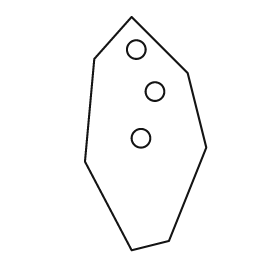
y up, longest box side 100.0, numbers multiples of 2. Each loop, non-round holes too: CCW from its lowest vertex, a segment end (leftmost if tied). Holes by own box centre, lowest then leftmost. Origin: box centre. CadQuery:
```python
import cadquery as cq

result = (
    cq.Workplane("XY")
    .moveTo(-6.0, -50.0)
    .lineTo(10.0, -46.0)
    .lineTo(26.0, -6.0)
    .lineTo(18.0, 26.0)
    .lineTo(-6.0, 50.0)
    .lineTo(-22.0, 32.0)
    .lineTo(-26.0, -12.0)
    .close()
    .moveTo(-2.0, -2.0)
    .circle(4.0)
    .moveTo(4.0, 18.0)
    .circle(4.0)
    .moveTo(-4.0, 36.0)
    .circle(4.0)
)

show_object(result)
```